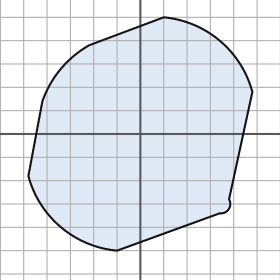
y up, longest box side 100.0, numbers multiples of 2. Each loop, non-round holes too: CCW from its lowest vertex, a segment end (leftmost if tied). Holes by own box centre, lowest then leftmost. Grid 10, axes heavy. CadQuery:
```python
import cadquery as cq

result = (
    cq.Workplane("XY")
    .moveTo(-10.0, -50.0)
    .lineTo(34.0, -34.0)
    .threePointArc((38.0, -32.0), (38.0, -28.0))
    .lineTo(48.0, 18.0)
    .threePointArc((34.0, 40.0), (10.0, 50.0))
    .lineTo(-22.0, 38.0)
    .threePointArc((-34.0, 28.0), (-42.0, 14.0))
    .lineTo(-48.0, -18.0)
    .threePointArc((-34.0, -40.0), (-10.0, -50.0))
    .close()
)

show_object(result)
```